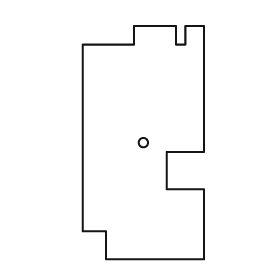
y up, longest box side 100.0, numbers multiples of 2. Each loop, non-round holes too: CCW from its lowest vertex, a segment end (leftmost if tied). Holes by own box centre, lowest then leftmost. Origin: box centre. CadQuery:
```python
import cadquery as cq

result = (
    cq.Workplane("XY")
    .moveTo(-16.0, -50.0)
    .lineTo(26.0, -50.0)
    .lineTo(26.0, -20.0)
    .lineTo(10.0, -20.0)
    .lineTo(10.0, -4.0)
    .lineTo(26.0, -4.0)
    .lineTo(26.0, 50.0)
    .lineTo(18.0, 50.0)
    .lineTo(18.0, 42.0)
    .lineTo(14.0, 42.0)
    .lineTo(14.0, 50.0)
    .lineTo(-4.0, 50.0)
    .lineTo(-4.0, 42.0)
    .lineTo(-26.0, 42.0)
    .lineTo(-26.0, -38.0)
    .lineTo(-16.0, -38.0)
    .close()
    .moveTo(0.0, 0.0)
    .circle(2.0)
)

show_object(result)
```